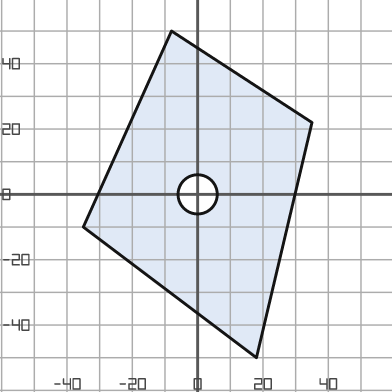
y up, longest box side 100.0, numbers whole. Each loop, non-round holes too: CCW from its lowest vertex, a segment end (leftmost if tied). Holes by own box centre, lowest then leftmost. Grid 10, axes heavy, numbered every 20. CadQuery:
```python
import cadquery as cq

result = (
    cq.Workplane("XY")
    .moveTo(18.0, -50.0)
    .lineTo(35.0, 22.0)
    .lineTo(-8.0, 50.0)
    .lineTo(-35.0, -10.0)
    .close()
    .moveTo(0.0, 0.0)
    .circle(6.0)
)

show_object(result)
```